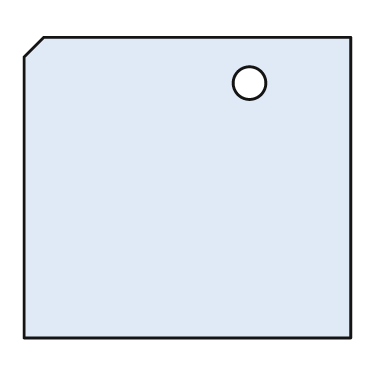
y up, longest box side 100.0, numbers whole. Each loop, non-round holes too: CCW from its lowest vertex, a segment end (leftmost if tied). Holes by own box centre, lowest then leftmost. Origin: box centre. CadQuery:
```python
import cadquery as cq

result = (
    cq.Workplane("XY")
    .moveTo(-50.0, -46.0)
    .lineTo(50.0, -46.0)
    .lineTo(50.0, 46.0)
    .lineTo(-44.0, 46.0)
    .lineTo(-50.0, 40.0)
    .close()
    .moveTo(19.0, 32.0)
    .circle(5.0)
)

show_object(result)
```